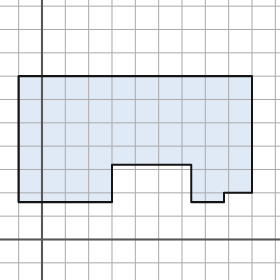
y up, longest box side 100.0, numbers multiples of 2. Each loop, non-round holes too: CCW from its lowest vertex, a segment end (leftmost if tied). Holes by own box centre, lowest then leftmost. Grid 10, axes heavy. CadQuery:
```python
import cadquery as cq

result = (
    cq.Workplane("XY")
    .moveTo(-10.0, 16.0)
    .lineTo(30.0, 16.0)
    .lineTo(30.0, 32.0)
    .lineTo(64.0, 32.0)
    .lineTo(64.0, 16.0)
    .lineTo(78.0, 16.0)
    .lineTo(78.0, 20.0)
    .lineTo(90.0, 20.0)
    .lineTo(90.0, 70.0)
    .lineTo(-10.0, 70.0)
    .close()
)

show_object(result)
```